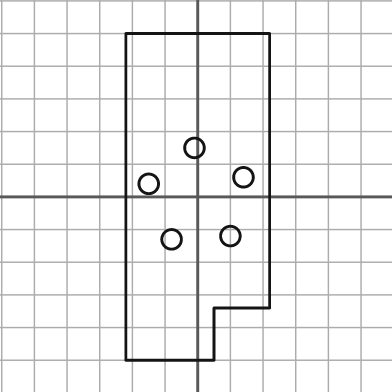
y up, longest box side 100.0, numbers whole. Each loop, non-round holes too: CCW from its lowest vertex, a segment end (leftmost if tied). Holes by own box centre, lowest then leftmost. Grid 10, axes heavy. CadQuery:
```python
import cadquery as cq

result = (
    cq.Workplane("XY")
    .moveTo(-22.0, -50.0)
    .lineTo(5.0, -50.0)
    .lineTo(5.0, -34.0)
    .lineTo(22.0, -34.0)
    .lineTo(22.0, 50.0)
    .lineTo(-22.0, 50.0)
    .close()
    .moveTo(-8.0, -13.0)
    .circle(3.0)
    .moveTo(10.0, -12.0)
    .circle(3.0)
    .moveTo(-15.0, 4.0)
    .circle(3.0)
    .moveTo(14.0, 6.0)
    .circle(3.0)
    .moveTo(-1.0, 15.0)
    .circle(3.0)
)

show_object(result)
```